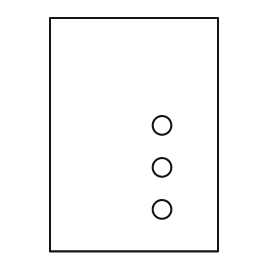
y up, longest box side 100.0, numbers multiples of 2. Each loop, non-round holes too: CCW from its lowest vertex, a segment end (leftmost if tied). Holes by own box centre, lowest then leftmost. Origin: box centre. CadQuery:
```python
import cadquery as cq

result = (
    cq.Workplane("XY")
    .moveTo(-36.0, -50.0)
    .lineTo(36.0, -50.0)
    .lineTo(36.0, 50.0)
    .lineTo(-36.0, 50.0)
    .close()
    .moveTo(12.0, -32.0)
    .circle(4.0)
    .moveTo(12.0, -14.0)
    .circle(4.0)
    .moveTo(12.0, 4.0)
    .circle(4.0)
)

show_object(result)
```